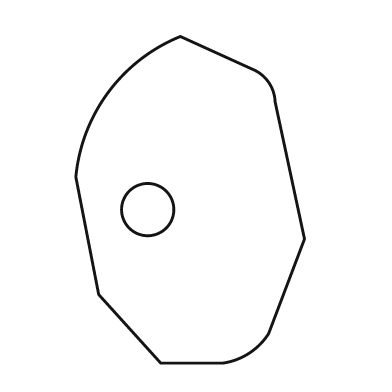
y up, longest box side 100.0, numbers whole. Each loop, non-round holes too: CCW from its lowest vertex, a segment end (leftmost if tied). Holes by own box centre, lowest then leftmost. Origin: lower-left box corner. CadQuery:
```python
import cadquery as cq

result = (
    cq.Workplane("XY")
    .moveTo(26.0, 0.0)
    .lineTo(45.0, 0.0)
    .threePointArc((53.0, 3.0), (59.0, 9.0))
    .lineTo(70.0, 38.0)
    .lineTo(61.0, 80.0)
    .threePointArc((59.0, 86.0), (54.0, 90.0))
    .lineTo(32.0, 100.0)
    .threePointArc((10.0, 83.0), (0.0, 57.0))
    .lineTo(7.0, 21.0)
    .close()
    .moveTo(22.0, 47.0)
    .circle(8.0)
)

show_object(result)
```